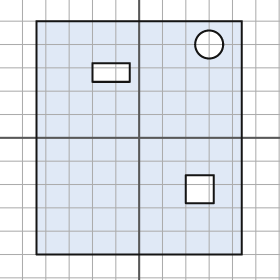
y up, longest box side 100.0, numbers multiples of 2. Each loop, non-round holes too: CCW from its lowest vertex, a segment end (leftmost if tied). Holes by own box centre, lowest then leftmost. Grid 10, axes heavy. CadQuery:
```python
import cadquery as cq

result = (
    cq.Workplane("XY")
    .moveTo(-44.0, -50.0)
    .lineTo(44.0, -50.0)
    .lineTo(44.0, 50.0)
    .lineTo(-44.0, 50.0)
    .close()
    .moveTo(20.0, -28.0)
    .lineTo(32.0, -28.0)
    .lineTo(32.0, -16.0)
    .lineTo(20.0, -16.0)
    .close()
    .moveTo(-20.0, 24.0)
    .lineTo(-4.0, 24.0)
    .lineTo(-4.0, 32.0)
    .lineTo(-20.0, 32.0)
    .close()
    .moveTo(30.0, 40.0)
    .circle(6.0)
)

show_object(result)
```